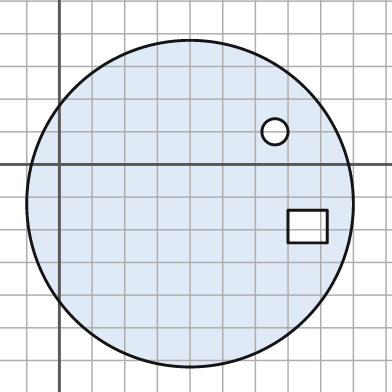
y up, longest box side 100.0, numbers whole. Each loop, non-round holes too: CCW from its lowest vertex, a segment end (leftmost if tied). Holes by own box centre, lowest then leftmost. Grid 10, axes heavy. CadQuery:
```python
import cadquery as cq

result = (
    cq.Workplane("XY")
    .moveTo(40.0, -12.0)
    .circle(50.0)
    .moveTo(70.0, -24.0)
    .lineTo(82.0, -24.0)
    .lineTo(82.0, -14.0)
    .lineTo(70.0, -14.0)
    .close()
    .moveTo(66.0, 10.0)
    .circle(4.0)
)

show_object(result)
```